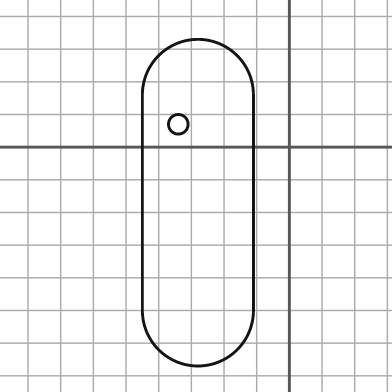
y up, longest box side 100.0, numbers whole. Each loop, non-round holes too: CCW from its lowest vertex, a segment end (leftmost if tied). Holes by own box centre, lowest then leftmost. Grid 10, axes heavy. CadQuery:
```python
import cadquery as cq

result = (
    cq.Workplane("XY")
    .moveTo(-45.0, -50.0)
    .threePointArc((-28.0, -67.0), (-11.0, -50.0))
    .lineTo(-11.0, 16.0)
    .threePointArc((-28.0, 33.0), (-45.0, 16.0))
    .close()
    .moveTo(-34.0, 7.0)
    .circle(3.0)
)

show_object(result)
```